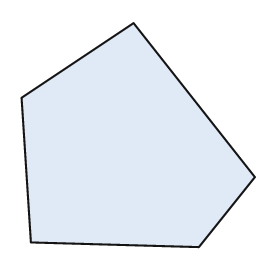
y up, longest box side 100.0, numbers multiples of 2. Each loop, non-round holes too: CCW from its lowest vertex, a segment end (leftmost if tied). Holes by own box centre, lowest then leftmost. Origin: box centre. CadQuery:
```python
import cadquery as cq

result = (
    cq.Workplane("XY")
    .moveTo(26.0, -48.0)
    .lineTo(50.0, -18.0)
    .lineTo(-2.0, 48.0)
    .lineTo(-50.0, 16.0)
    .lineTo(-46.0, -46.0)
    .close()
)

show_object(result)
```